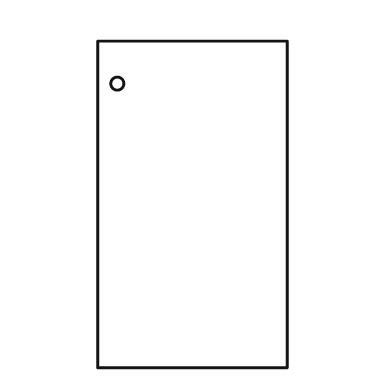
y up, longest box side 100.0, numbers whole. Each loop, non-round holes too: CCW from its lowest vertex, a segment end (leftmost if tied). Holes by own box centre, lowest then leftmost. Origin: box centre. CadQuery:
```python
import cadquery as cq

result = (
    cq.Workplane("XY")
    .moveTo(-29.0, -50.0)
    .lineTo(29.0, -50.0)
    .lineTo(29.0, 50.0)
    .lineTo(-29.0, 50.0)
    .close()
    .moveTo(-23.0, 37.0)
    .circle(2.0)
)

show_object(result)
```